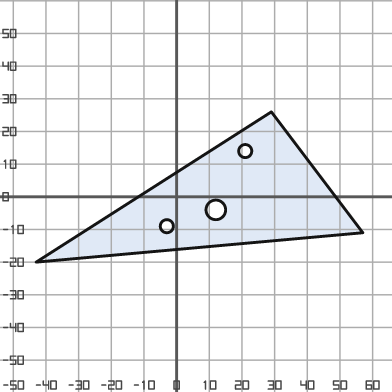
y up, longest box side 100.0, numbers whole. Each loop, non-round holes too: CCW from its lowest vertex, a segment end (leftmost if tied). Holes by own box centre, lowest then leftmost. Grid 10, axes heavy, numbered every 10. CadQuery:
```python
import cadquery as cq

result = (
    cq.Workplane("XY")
    .moveTo(-43.0, -20.0)
    .lineTo(57.0, -11.0)
    .lineTo(29.0, 26.0)
    .close()
    .moveTo(-3.0, -9.0)
    .circle(2.0)
    .moveTo(12.0, -4.0)
    .circle(3.0)
    .moveTo(21.0, 14.0)
    .circle(2.0)
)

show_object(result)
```